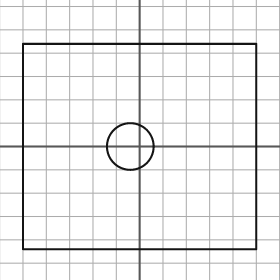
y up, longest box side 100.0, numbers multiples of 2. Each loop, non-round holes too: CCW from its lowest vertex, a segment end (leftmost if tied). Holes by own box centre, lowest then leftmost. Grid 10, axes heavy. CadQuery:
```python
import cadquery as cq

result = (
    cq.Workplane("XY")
    .moveTo(-50.0, -44.0)
    .lineTo(50.0, -44.0)
    .lineTo(50.0, 44.0)
    .lineTo(-50.0, 44.0)
    .close()
    .moveTo(-4.0, 0.0)
    .circle(10.0)
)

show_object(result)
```